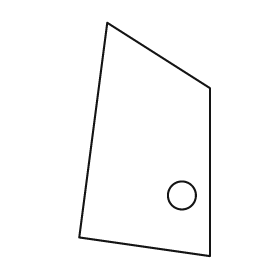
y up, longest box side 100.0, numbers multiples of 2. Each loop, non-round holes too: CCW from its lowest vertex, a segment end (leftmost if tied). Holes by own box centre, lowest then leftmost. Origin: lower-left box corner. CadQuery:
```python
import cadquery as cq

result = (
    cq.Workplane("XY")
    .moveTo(56.0, 0.0)
    .lineTo(56.0, 72.0)
    .lineTo(12.0, 100.0)
    .lineTo(0.0, 8.0)
    .close()
    .moveTo(44.0, 26.0)
    .circle(6.0)
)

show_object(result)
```